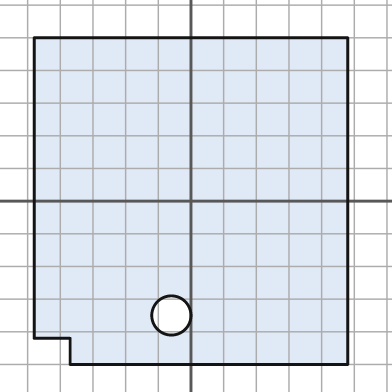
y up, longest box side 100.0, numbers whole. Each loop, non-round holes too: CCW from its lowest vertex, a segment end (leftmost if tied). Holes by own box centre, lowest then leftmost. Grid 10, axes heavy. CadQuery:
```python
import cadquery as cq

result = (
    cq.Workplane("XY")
    .moveTo(-37.0, -50.0)
    .lineTo(48.0, -50.0)
    .lineTo(48.0, 50.0)
    .lineTo(-48.0, 50.0)
    .lineTo(-48.0, -42.0)
    .lineTo(-37.0, -42.0)
    .close()
    .moveTo(-6.0, -35.0)
    .circle(6.0)
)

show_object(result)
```